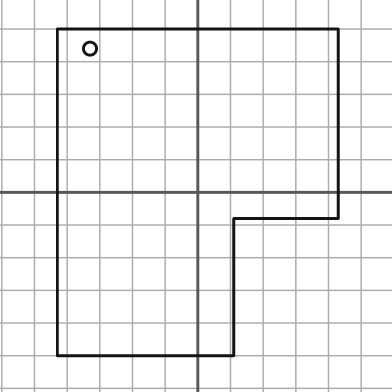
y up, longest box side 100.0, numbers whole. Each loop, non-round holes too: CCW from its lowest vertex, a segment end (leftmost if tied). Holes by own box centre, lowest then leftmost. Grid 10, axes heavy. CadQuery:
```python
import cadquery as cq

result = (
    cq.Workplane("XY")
    .moveTo(-43.0, -50.0)
    .lineTo(11.0, -50.0)
    .lineTo(11.0, -8.0)
    .lineTo(43.0, -8.0)
    .lineTo(43.0, 50.0)
    .lineTo(-43.0, 50.0)
    .close()
    .moveTo(-33.0, 44.0)
    .circle(2.0)
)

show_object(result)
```